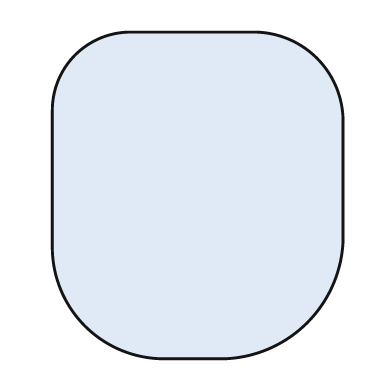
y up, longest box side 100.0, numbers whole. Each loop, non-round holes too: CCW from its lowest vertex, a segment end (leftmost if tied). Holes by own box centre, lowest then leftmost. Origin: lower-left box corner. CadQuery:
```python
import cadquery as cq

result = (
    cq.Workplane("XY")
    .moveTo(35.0, 0.0)
    .lineTo(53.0, 0.0)
    .threePointArc((78.0, 11.0), (89.0, 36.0))
    .lineTo(89.0, 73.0)
    .threePointArc((81.0, 92.0), (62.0, 100.0))
    .lineTo(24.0, 100.0)
    .threePointArc((7.0, 93.0), (0.0, 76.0))
    .lineTo(0.0, 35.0)
    .threePointArc((10.0, 10.0), (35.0, 0.0))
    .close()
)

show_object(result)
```